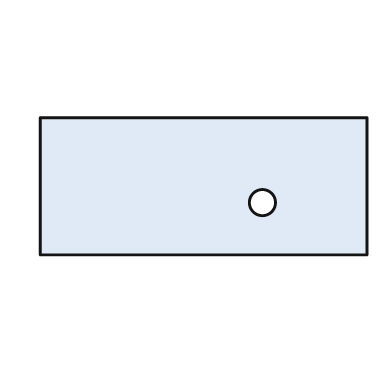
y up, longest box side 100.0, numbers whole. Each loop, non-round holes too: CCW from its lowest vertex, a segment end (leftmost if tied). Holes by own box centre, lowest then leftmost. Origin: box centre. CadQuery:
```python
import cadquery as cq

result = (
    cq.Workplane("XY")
    .moveTo(-50.0, -21.0)
    .lineTo(50.0, -21.0)
    .lineTo(50.0, 21.0)
    .lineTo(-50.0, 21.0)
    .close()
    .moveTo(18.0, -5.0)
    .circle(4.0)
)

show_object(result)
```